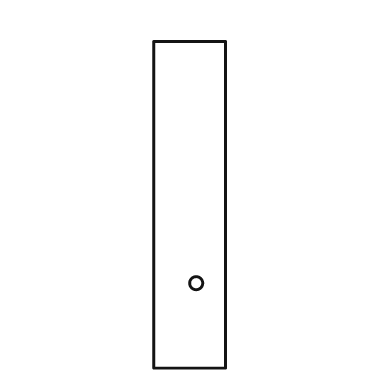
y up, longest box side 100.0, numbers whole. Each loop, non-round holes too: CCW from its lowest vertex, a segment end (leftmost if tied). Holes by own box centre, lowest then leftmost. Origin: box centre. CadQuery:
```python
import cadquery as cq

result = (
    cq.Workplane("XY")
    .moveTo(-11.0, -50.0)
    .lineTo(11.0, -50.0)
    .lineTo(11.0, 50.0)
    .lineTo(-11.0, 50.0)
    .close()
    .moveTo(2.0, -24.0)
    .circle(2.0)
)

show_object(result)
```